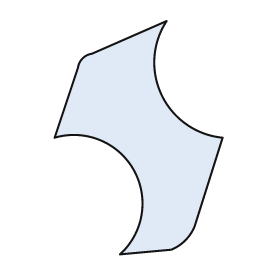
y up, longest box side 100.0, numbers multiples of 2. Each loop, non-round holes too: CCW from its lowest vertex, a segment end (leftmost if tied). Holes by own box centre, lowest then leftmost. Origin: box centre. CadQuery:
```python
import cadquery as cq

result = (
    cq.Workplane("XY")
    .moveTo(-8.0, -50.0)
    .lineTo(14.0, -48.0)
    .threePointArc((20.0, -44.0), (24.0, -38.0))
    .lineTo(36.0, 0.0)
    .threePointArc((10.0, 18.0), (12.0, 50.0))
    .lineTo(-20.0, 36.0)
    .threePointArc((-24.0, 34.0), (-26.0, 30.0))
    .lineTo(-36.0, 0.0)
    .threePointArc((-2.0, -14.0), (-8.0, -50.0))
    .close()
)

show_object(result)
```